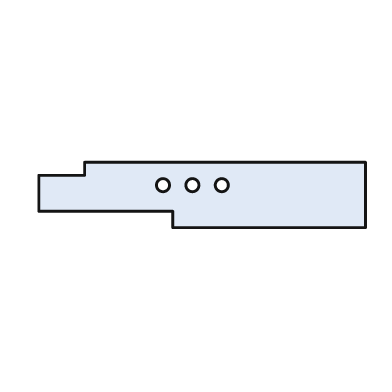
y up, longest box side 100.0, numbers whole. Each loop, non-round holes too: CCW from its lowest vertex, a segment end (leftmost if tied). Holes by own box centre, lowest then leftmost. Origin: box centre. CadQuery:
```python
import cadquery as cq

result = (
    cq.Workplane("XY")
    .moveTo(-9.0, -10.0)
    .lineTo(50.0, -10.0)
    .lineTo(50.0, 10.0)
    .lineTo(-36.0, 10.0)
    .lineTo(-36.0, 6.0)
    .lineTo(-50.0, 6.0)
    .lineTo(-50.0, -5.0)
    .lineTo(-9.0, -5.0)
    .close()
    .moveTo(-12.0, 3.0)
    .circle(2.0)
    .moveTo(-3.0, 3.0)
    .circle(2.0)
    .moveTo(6.0, 3.0)
    .circle(2.0)
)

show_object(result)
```